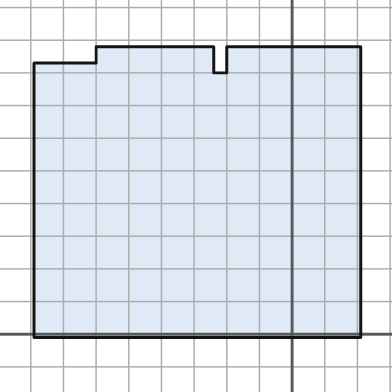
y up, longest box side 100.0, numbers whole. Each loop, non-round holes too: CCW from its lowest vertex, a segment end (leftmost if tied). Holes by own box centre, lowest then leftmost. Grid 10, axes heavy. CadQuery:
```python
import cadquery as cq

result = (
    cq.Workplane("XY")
    .moveTo(-79.0, -1.0)
    .lineTo(21.0, -1.0)
    .lineTo(21.0, 88.0)
    .lineTo(-20.0, 88.0)
    .lineTo(-20.0, 80.0)
    .lineTo(-24.0, 80.0)
    .lineTo(-24.0, 88.0)
    .lineTo(-60.0, 88.0)
    .lineTo(-60.0, 83.0)
    .lineTo(-79.0, 83.0)
    .close()
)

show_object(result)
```